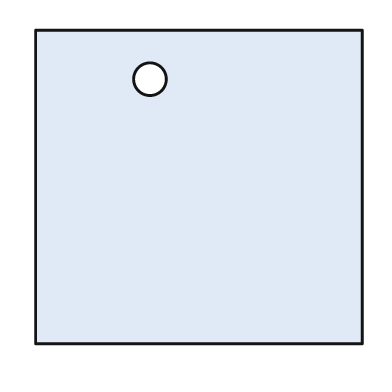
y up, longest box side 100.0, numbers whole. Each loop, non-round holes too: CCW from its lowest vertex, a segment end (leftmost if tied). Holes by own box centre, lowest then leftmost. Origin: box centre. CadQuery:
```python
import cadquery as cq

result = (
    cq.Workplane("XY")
    .moveTo(-50.0, -48.0)
    .lineTo(50.0, -48.0)
    .lineTo(50.0, 48.0)
    .lineTo(-50.0, 48.0)
    .close()
    .moveTo(-15.0, 33.0)
    .circle(5.0)
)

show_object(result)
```